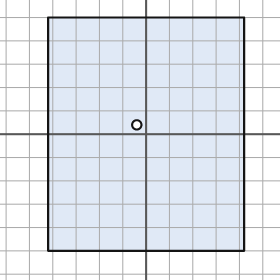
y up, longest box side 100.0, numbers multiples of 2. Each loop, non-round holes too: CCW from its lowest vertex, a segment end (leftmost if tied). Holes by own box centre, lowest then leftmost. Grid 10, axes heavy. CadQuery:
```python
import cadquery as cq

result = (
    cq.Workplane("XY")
    .moveTo(-42.0, -50.0)
    .lineTo(42.0, -50.0)
    .lineTo(42.0, 50.0)
    .lineTo(-42.0, 50.0)
    .close()
    .moveTo(-4.0, 4.0)
    .circle(2.0)
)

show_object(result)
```